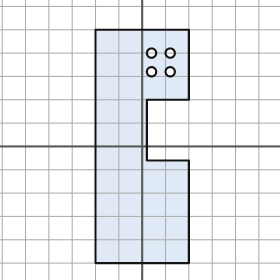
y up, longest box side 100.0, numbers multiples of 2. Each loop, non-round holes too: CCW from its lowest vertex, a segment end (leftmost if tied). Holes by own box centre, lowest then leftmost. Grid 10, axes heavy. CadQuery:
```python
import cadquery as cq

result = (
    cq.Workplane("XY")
    .moveTo(-20.0, -50.0)
    .lineTo(20.0, -50.0)
    .lineTo(20.0, -6.0)
    .lineTo(2.0, -6.0)
    .lineTo(2.0, 20.0)
    .lineTo(20.0, 20.0)
    .lineTo(20.0, 50.0)
    .lineTo(-20.0, 50.0)
    .close()
    .moveTo(4.0, 32.0)
    .circle(2.0)
    .moveTo(12.0, 32.0)
    .circle(2.0)
    .moveTo(4.0, 40.0)
    .circle(2.0)
    .moveTo(12.0, 40.0)
    .circle(2.0)
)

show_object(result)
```